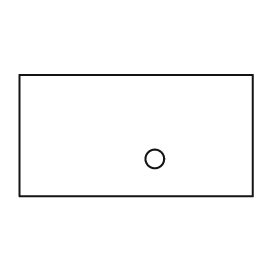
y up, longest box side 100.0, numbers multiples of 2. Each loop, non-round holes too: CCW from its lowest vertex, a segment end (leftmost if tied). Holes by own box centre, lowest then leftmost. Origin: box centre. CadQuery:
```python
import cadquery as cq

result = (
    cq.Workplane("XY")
    .moveTo(-50.0, -26.0)
    .lineTo(50.0, -26.0)
    .lineTo(50.0, 26.0)
    .lineTo(-50.0, 26.0)
    .close()
    .moveTo(8.0, -10.0)
    .circle(4.0)
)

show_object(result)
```